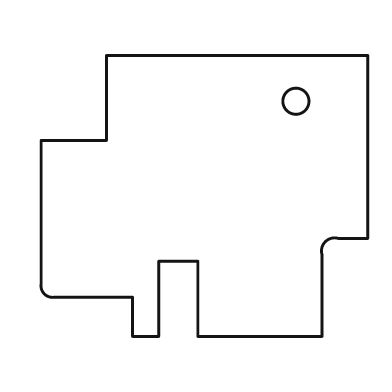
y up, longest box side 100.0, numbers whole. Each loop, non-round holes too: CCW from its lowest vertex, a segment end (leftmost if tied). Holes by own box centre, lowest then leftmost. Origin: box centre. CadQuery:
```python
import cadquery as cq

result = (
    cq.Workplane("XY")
    .moveTo(-22.0, -43.0)
    .lineTo(-14.0, -43.0)
    .lineTo(-14.0, -20.0)
    .lineTo(-2.0, -20.0)
    .lineTo(-2.0, -43.0)
    .lineTo(36.0, -43.0)
    .lineTo(36.0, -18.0)
    .threePointArc((37.0, -14.0), (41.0, -13.0))
    .lineTo(50.0, -13.0)
    .lineTo(50.0, 43.0)
    .lineTo(-30.0, 43.0)
    .lineTo(-30.0, 17.0)
    .lineTo(-50.0, 17.0)
    .lineTo(-50.0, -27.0)
    .threePointArc((-49.0, -30.0), (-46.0, -31.0))
    .lineTo(-22.0, -31.0)
    .close()
    .moveTo(28.0, 29.0)
    .circle(4.0)
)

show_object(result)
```